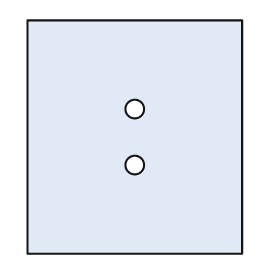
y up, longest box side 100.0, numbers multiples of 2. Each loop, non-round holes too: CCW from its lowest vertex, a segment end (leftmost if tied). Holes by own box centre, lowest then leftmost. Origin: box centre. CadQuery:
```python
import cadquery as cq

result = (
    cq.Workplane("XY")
    .moveTo(-46.0, -50.0)
    .lineTo(46.0, -50.0)
    .lineTo(46.0, 50.0)
    .lineTo(-46.0, 50.0)
    .close()
    .moveTo(0.0, -12.0)
    .circle(4.0)
    .moveTo(0.0, 12.0)
    .circle(4.0)
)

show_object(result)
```